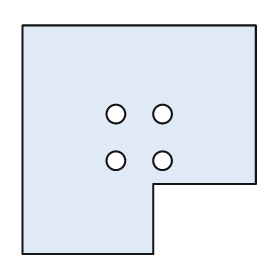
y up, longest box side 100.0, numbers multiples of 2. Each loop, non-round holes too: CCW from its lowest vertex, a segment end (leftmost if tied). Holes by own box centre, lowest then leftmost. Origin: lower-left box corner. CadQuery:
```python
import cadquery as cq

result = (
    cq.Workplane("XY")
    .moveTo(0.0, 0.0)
    .lineTo(56.0, 0.0)
    .lineTo(56.0, 30.0)
    .lineTo(100.0, 30.0)
    .lineTo(100.0, 98.0)
    .lineTo(0.0, 98.0)
    .close()
    .moveTo(40.0, 40.0)
    .circle(4.0)
    .moveTo(60.0, 40.0)
    .circle(4.0)
    .moveTo(40.0, 60.0)
    .circle(4.0)
    .moveTo(60.0, 60.0)
    .circle(4.0)
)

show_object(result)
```